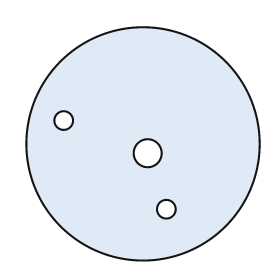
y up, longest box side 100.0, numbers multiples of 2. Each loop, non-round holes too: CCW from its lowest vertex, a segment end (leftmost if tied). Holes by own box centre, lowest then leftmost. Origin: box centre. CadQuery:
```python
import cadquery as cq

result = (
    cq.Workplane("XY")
    .moveTo(0.0, 0.0)
    .circle(50.0)
    .moveTo(10.0, -28.0)
    .circle(4.0)
    .moveTo(2.0, -4.0)
    .circle(6.0)
    .moveTo(-34.0, 10.0)
    .circle(4.0)
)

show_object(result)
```